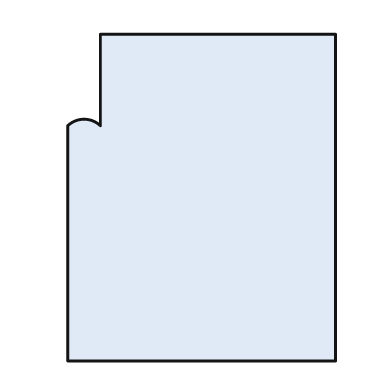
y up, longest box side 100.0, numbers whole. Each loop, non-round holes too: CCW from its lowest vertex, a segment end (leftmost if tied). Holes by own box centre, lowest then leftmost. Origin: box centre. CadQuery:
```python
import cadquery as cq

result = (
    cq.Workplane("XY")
    .moveTo(-41.0, -50.0)
    .lineTo(41.0, -50.0)
    .lineTo(41.0, 50.0)
    .lineTo(-31.0, 50.0)
    .lineTo(-31.0, 22.0)
    .threePointArc((-36.0, 24.0), (-41.0, 22.0))
    .close()
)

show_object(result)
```